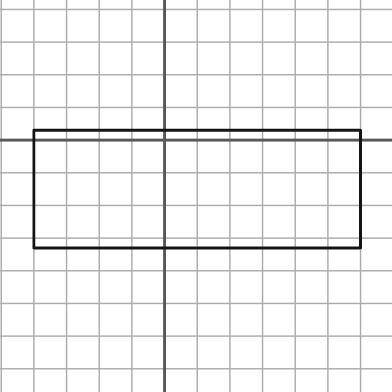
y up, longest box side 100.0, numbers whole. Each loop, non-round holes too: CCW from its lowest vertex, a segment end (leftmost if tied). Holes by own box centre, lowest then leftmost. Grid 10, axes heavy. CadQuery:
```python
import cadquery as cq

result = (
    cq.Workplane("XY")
    .moveTo(-40.0, -33.0)
    .lineTo(60.0, -33.0)
    .lineTo(60.0, 3.0)
    .lineTo(-40.0, 3.0)
    .close()
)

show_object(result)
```